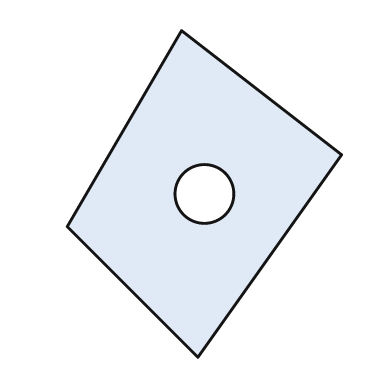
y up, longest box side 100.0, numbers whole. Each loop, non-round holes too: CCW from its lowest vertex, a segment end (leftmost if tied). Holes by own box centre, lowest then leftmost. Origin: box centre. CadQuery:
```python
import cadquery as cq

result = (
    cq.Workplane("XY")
    .moveTo(-2.0, -50.0)
    .lineTo(42.0, 12.0)
    .lineTo(-7.0, 50.0)
    .lineTo(-42.0, -10.0)
    .close()
    .moveTo(0.0, 0.0)
    .circle(9.0)
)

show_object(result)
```